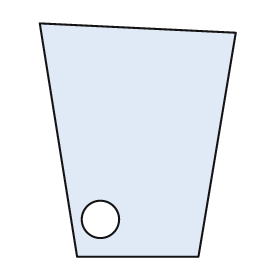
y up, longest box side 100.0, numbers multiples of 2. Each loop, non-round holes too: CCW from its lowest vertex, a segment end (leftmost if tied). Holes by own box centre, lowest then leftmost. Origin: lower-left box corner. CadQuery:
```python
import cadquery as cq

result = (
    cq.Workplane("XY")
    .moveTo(16.0, 0.0)
    .lineTo(68.0, 0.0)
    .lineTo(84.0, 96.0)
    .lineTo(0.0, 100.0)
    .close()
    .moveTo(26.0, 16.0)
    .circle(8.0)
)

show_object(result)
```